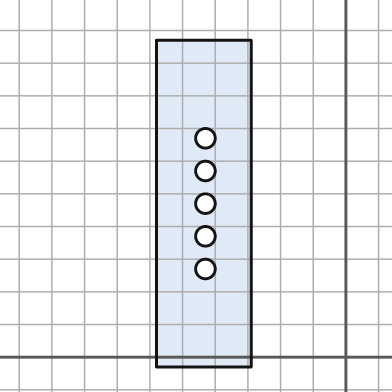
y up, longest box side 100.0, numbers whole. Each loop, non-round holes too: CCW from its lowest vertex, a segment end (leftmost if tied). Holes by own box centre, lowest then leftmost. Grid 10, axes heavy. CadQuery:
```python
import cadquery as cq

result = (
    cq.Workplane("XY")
    .moveTo(-58.0, -3.0)
    .lineTo(-29.0, -3.0)
    .lineTo(-29.0, 97.0)
    .lineTo(-58.0, 97.0)
    .close()
    .moveTo(-43.0, 27.0)
    .circle(3.0)
    .moveTo(-43.0, 37.0)
    .circle(3.0)
    .moveTo(-43.0, 47.0)
    .circle(3.0)
    .moveTo(-43.0, 57.0)
    .circle(3.0)
    .moveTo(-43.0, 67.0)
    .circle(3.0)
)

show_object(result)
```